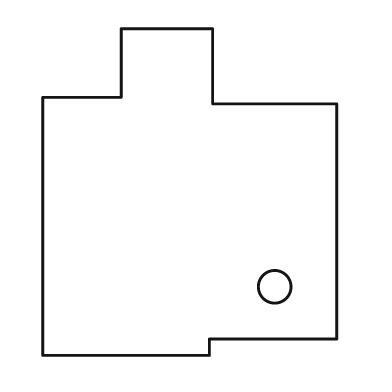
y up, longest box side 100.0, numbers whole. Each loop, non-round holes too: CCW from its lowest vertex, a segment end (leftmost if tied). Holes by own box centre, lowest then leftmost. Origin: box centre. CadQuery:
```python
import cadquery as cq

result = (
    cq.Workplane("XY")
    .moveTo(-45.0, -50.0)
    .lineTo(6.0, -50.0)
    .lineTo(6.0, -45.0)
    .lineTo(45.0, -45.0)
    .lineTo(45.0, 27.0)
    .lineTo(7.0, 27.0)
    .lineTo(7.0, 50.0)
    .lineTo(-21.0, 50.0)
    .lineTo(-21.0, 29.0)
    .lineTo(-45.0, 29.0)
    .close()
    .moveTo(26.0, -29.0)
    .circle(5.0)
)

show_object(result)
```